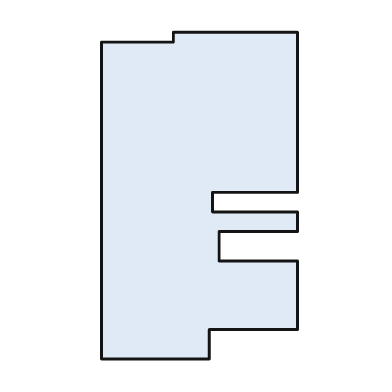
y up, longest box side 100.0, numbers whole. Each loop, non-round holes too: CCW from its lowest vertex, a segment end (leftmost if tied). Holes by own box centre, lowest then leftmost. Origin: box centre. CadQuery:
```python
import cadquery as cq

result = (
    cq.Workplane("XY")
    .moveTo(-30.0, -50.0)
    .lineTo(3.0, -50.0)
    .lineTo(3.0, -41.0)
    .lineTo(30.0, -41.0)
    .lineTo(30.0, -20.0)
    .lineTo(6.0, -20.0)
    .lineTo(6.0, -11.0)
    .lineTo(30.0, -11.0)
    .lineTo(30.0, -5.0)
    .lineTo(4.0, -5.0)
    .lineTo(4.0, 1.0)
    .lineTo(30.0, 1.0)
    .lineTo(30.0, 50.0)
    .lineTo(-8.0, 50.0)
    .lineTo(-8.0, 47.0)
    .lineTo(-30.0, 47.0)
    .close()
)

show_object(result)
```